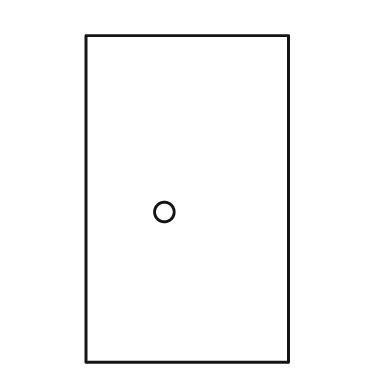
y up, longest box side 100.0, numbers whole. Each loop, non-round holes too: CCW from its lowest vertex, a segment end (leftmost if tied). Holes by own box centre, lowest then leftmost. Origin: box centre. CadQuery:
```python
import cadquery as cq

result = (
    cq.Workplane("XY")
    .moveTo(-31.0, -50.0)
    .lineTo(31.0, -50.0)
    .lineTo(31.0, 50.0)
    .lineTo(-31.0, 50.0)
    .close()
    .moveTo(-7.0, -4.0)
    .circle(3.0)
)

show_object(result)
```